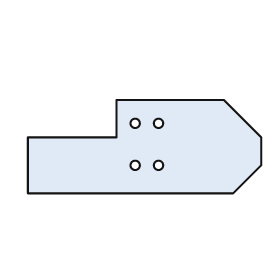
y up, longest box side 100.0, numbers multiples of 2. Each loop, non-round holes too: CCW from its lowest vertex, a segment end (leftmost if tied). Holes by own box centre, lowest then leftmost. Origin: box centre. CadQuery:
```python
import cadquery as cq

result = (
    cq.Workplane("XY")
    .moveTo(-50.0, -20.0)
    .lineTo(38.0, -20.0)
    .lineTo(50.0, -8.0)
    .lineTo(50.0, 4.0)
    .lineTo(34.0, 20.0)
    .lineTo(-12.0, 20.0)
    .lineTo(-12.0, 4.0)
    .lineTo(-50.0, 4.0)
    .close()
    .moveTo(-4.0, -8.0)
    .circle(2.0)
    .moveTo(6.0, -8.0)
    .circle(2.0)
    .moveTo(-4.0, 10.0)
    .circle(2.0)
    .moveTo(6.0, 10.0)
    .circle(2.0)
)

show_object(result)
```